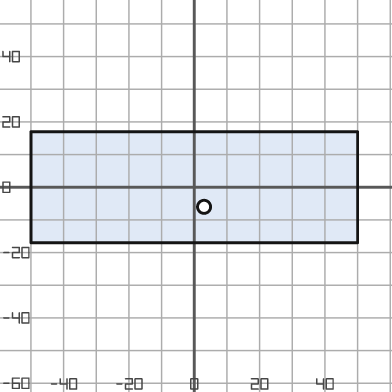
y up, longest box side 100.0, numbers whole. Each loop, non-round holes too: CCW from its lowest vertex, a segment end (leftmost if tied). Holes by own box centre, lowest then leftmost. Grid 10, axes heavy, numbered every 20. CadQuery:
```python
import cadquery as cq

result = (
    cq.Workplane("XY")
    .moveTo(-50.0, -17.0)
    .lineTo(50.0, -17.0)
    .lineTo(50.0, 17.0)
    .lineTo(-50.0, 17.0)
    .close()
    .moveTo(3.0, -6.0)
    .circle(2.0)
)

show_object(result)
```